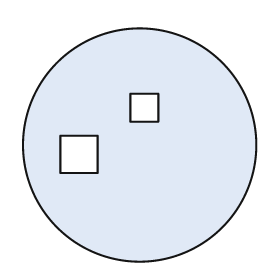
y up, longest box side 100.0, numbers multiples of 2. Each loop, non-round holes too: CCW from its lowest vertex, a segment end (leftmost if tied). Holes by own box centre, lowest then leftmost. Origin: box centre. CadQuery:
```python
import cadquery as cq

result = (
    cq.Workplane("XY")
    .moveTo(0.0, 0.0)
    .circle(50.0)
    .moveTo(-34.0, -12.0)
    .lineTo(-18.0, -12.0)
    .lineTo(-18.0, 4.0)
    .lineTo(-34.0, 4.0)
    .close()
    .moveTo(-4.0, 10.0)
    .lineTo(8.0, 10.0)
    .lineTo(8.0, 22.0)
    .lineTo(-4.0, 22.0)
    .close()
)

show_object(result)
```